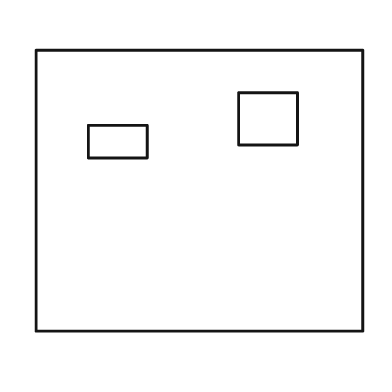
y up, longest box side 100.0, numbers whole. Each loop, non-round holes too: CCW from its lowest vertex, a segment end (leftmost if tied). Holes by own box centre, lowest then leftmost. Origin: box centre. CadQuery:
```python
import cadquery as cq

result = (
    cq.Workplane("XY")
    .moveTo(-50.0, -43.0)
    .lineTo(50.0, -43.0)
    .lineTo(50.0, 43.0)
    .lineTo(-50.0, 43.0)
    .close()
    .moveTo(-34.0, 10.0)
    .lineTo(-16.0, 10.0)
    .lineTo(-16.0, 20.0)
    .lineTo(-34.0, 20.0)
    .close()
    .moveTo(12.0, 14.0)
    .lineTo(30.0, 14.0)
    .lineTo(30.0, 30.0)
    .lineTo(12.0, 30.0)
    .close()
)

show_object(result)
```